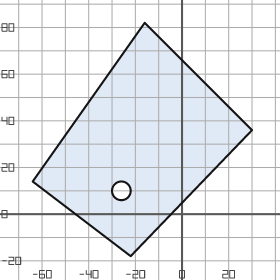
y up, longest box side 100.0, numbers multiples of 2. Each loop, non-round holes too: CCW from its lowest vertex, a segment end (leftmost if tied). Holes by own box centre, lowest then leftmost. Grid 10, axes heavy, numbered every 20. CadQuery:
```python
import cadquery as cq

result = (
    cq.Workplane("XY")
    .moveTo(-22.0, -18.0)
    .lineTo(30.0, 36.0)
    .lineTo(-16.0, 82.0)
    .lineTo(-64.0, 14.0)
    .close()
    .moveTo(-26.0, 10.0)
    .circle(4.0)
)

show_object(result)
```